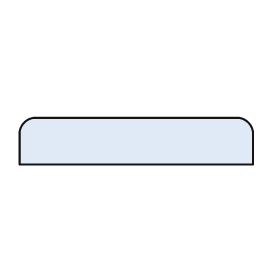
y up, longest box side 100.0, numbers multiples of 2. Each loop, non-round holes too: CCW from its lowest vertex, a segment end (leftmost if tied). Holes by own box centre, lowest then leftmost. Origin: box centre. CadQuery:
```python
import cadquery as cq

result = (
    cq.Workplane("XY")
    .moveTo(-50.0, -10.0)
    .lineTo(50.0, -10.0)
    .lineTo(50.0, 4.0)
    .threePointArc((48.0, 8.0), (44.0, 10.0))
    .lineTo(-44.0, 10.0)
    .threePointArc((-48.0, 8.0), (-50.0, 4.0))
    .close()
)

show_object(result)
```